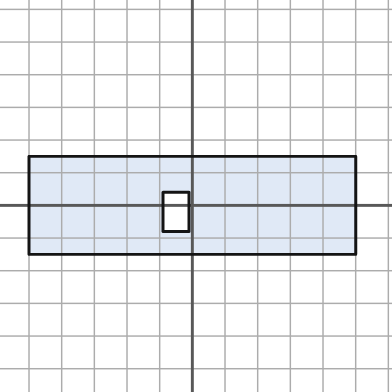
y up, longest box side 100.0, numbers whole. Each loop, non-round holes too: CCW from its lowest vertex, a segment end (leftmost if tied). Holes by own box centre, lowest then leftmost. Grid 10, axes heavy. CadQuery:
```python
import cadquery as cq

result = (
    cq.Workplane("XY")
    .moveTo(-50.0, -15.0)
    .lineTo(50.0, -15.0)
    .lineTo(50.0, 15.0)
    .lineTo(-50.0, 15.0)
    .close()
    .moveTo(-9.0, -8.0)
    .lineTo(-1.0, -8.0)
    .lineTo(-1.0, 4.0)
    .lineTo(-9.0, 4.0)
    .close()
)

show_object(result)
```